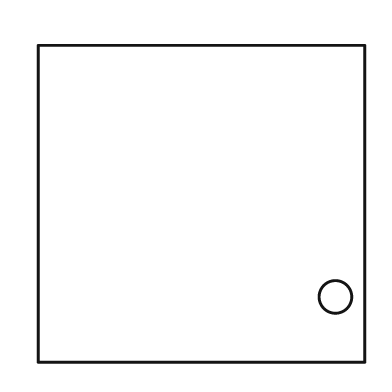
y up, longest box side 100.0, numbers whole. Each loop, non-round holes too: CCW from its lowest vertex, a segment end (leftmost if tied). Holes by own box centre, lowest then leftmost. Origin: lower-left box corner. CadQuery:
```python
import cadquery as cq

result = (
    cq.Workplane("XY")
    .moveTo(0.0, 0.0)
    .lineTo(100.0, 0.0)
    .lineTo(100.0, 97.0)
    .lineTo(0.0, 97.0)
    .close()
    .moveTo(91.0, 20.0)
    .circle(5.0)
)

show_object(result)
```